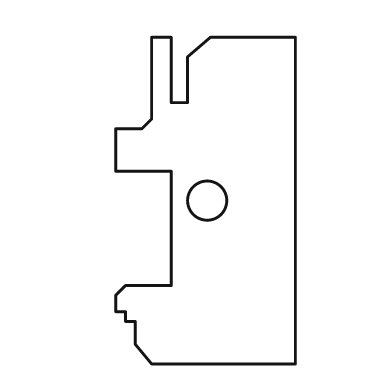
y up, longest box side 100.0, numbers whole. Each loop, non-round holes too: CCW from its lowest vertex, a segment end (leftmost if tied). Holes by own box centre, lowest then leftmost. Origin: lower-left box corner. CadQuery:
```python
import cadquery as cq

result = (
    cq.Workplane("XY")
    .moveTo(11.0, 0.0)
    .lineTo(55.0, 0.0)
    .lineTo(55.0, 100.0)
    .lineTo(29.0, 100.0)
    .lineTo(22.0, 94.0)
    .lineTo(22.0, 80.0)
    .lineTo(17.0, 80.0)
    .lineTo(17.0, 100.0)
    .lineTo(11.0, 100.0)
    .lineTo(11.0, 75.0)
    .lineTo(8.0, 72.0)
    .lineTo(0.0, 72.0)
    .lineTo(0.0, 59.0)
    .lineTo(17.0, 59.0)
    .lineTo(17.0, 24.0)
    .lineTo(3.0, 24.0)
    .lineTo(0.0, 21.0)
    .lineTo(0.0, 16.0)
    .lineTo(3.0, 16.0)
    .lineTo(3.0, 13.0)
    .lineTo(6.0, 13.0)
    .lineTo(6.0, 6.0)
    .close()
    .moveTo(28.0, 50.0)
    .circle(6.0)
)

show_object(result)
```